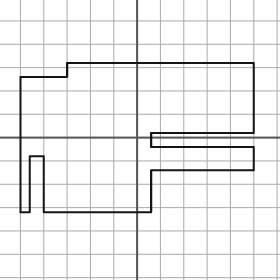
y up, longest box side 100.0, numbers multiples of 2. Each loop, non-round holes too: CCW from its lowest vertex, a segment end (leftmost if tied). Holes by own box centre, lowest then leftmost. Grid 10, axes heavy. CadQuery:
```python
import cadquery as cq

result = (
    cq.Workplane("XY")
    .moveTo(-50.0, -32.0)
    .lineTo(-46.0, -32.0)
    .lineTo(-46.0, -8.0)
    .lineTo(-40.0, -8.0)
    .lineTo(-40.0, -32.0)
    .lineTo(6.0, -32.0)
    .lineTo(6.0, -14.0)
    .lineTo(50.0, -14.0)
    .lineTo(50.0, -4.0)
    .lineTo(6.0, -4.0)
    .lineTo(6.0, 2.0)
    .lineTo(50.0, 2.0)
    .lineTo(50.0, 32.0)
    .lineTo(-30.0, 32.0)
    .lineTo(-30.0, 26.0)
    .lineTo(-50.0, 26.0)
    .close()
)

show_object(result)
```